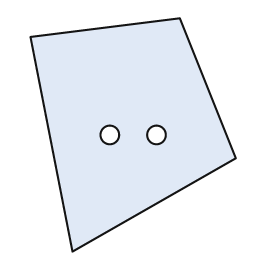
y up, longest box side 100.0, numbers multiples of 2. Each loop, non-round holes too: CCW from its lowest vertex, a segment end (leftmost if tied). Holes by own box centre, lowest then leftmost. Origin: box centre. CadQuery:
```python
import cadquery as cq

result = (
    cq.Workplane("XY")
    .moveTo(-26.0, -50.0)
    .lineTo(44.0, -10.0)
    .lineTo(20.0, 50.0)
    .lineTo(-44.0, 42.0)
    .close()
    .moveTo(-10.0, 0.0)
    .circle(4.0)
    .moveTo(10.0, 0.0)
    .circle(4.0)
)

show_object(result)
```